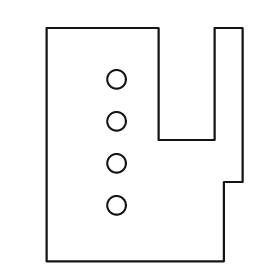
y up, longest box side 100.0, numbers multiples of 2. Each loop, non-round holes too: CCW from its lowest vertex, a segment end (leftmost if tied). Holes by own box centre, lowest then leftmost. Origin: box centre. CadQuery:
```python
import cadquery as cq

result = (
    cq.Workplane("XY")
    .moveTo(-42.0, -50.0)
    .lineTo(34.0, -50.0)
    .lineTo(34.0, -16.0)
    .lineTo(42.0, -16.0)
    .lineTo(42.0, 50.0)
    .lineTo(30.0, 50.0)
    .lineTo(30.0, 2.0)
    .lineTo(6.0, 2.0)
    .lineTo(6.0, 50.0)
    .lineTo(-42.0, 50.0)
    .close()
    .moveTo(-12.0, -26.0)
    .circle(4.0)
    .moveTo(-12.0, -8.0)
    .circle(4.0)
    .moveTo(-12.0, 10.0)
    .circle(4.0)
    .moveTo(-12.0, 28.0)
    .circle(4.0)
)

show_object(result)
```